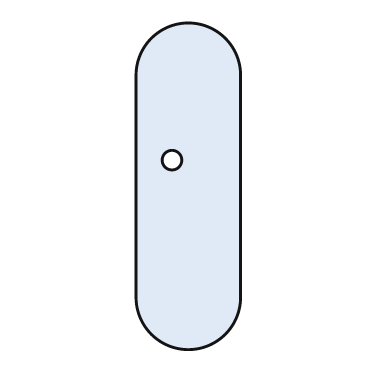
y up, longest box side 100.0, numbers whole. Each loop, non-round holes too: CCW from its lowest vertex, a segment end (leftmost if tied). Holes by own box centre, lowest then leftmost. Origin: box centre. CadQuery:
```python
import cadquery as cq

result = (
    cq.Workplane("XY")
    .moveTo(-16.0, -34.0)
    .threePointArc((0.0, -50.0), (16.0, -34.0))
    .lineTo(16.0, 34.0)
    .threePointArc((0.0, 50.0), (-16.0, 34.0))
    .close()
    .moveTo(-5.0, 8.0)
    .circle(3.0)
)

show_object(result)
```